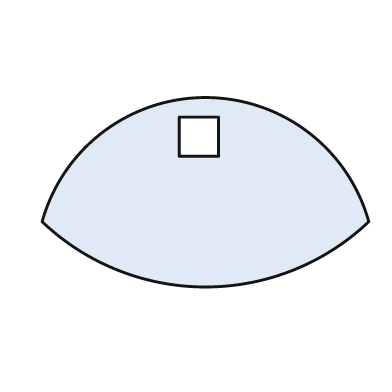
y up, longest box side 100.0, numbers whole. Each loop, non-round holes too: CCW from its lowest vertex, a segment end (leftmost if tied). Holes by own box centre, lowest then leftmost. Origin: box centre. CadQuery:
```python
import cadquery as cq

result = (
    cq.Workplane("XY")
    .moveTo(-50.0, -9.0)
    .threePointArc((0.0, -29.0), (50.0, -9.0))
    .threePointArc((0.0, 29.0), (-50.0, -9.0))
    .close()
    .moveTo(-8.0, 11.0)
    .lineTo(4.0, 11.0)
    .lineTo(4.0, 23.0)
    .lineTo(-8.0, 23.0)
    .close()
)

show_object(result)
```